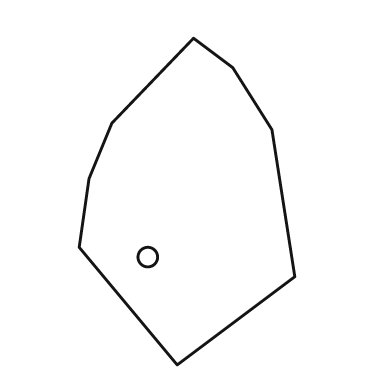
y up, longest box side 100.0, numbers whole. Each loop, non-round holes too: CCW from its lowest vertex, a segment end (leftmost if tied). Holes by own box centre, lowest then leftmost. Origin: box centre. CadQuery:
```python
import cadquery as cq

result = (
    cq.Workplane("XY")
    .moveTo(-3.0, -50.0)
    .lineTo(33.0, -23.0)
    .lineTo(26.0, 22.0)
    .lineTo(14.0, 41.0)
    .lineTo(2.0, 50.0)
    .lineTo(-23.0, 24.0)
    .lineTo(-30.0, 7.0)
    .lineTo(-33.0, -14.0)
    .close()
    .moveTo(-12.0, -17.0)
    .circle(3.0)
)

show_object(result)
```